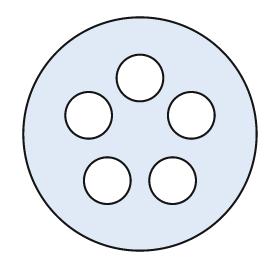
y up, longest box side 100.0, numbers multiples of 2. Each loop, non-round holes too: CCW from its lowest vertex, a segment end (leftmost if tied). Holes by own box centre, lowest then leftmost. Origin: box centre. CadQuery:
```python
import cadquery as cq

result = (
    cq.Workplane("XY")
    .moveTo(0.0, 0.0)
    .circle(50.0)
    .moveTo(-14.0, -20.0)
    .circle(10.0)
    .moveTo(14.0, -20.0)
    .circle(10.0)
    .moveTo(-22.0, 8.0)
    .circle(10.0)
    .moveTo(22.0, 8.0)
    .circle(10.0)
    .moveTo(0.0, 24.0)
    .circle(10.0)
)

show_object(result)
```